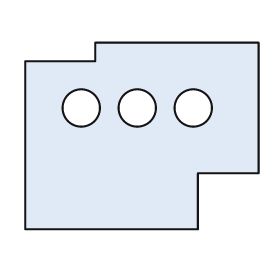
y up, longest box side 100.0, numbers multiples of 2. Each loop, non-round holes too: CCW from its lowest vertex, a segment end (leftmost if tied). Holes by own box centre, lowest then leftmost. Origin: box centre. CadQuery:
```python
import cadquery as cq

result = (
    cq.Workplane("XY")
    .moveTo(-50.0, -40.0)
    .lineTo(24.0, -40.0)
    .lineTo(24.0, -16.0)
    .lineTo(50.0, -16.0)
    .lineTo(50.0, 40.0)
    .lineTo(-20.0, 40.0)
    .lineTo(-20.0, 32.0)
    .lineTo(-50.0, 32.0)
    .close()
    .moveTo(-26.0, 12.0)
    .circle(8.0)
    .moveTo(-2.0, 12.0)
    .circle(8.0)
    .moveTo(22.0, 12.0)
    .circle(8.0)
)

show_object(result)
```